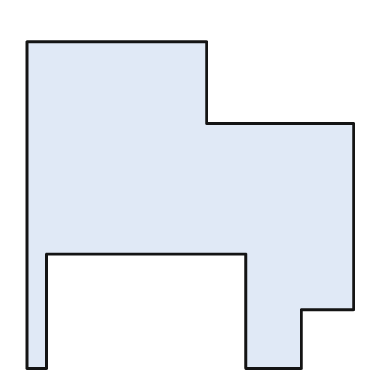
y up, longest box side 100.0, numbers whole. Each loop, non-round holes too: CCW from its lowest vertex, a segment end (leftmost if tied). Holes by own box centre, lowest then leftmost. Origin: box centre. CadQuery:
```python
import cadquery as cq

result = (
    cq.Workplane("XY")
    .moveTo(-50.0, -50.0)
    .lineTo(-44.0, -50.0)
    .lineTo(-44.0, -15.0)
    .lineTo(17.0, -15.0)
    .lineTo(17.0, -50.0)
    .lineTo(34.0, -50.0)
    .lineTo(34.0, -32.0)
    .lineTo(50.0, -32.0)
    .lineTo(50.0, 25.0)
    .lineTo(5.0, 25.0)
    .lineTo(5.0, 50.0)
    .lineTo(-50.0, 50.0)
    .close()
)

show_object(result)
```